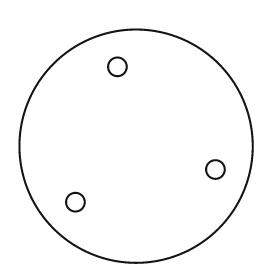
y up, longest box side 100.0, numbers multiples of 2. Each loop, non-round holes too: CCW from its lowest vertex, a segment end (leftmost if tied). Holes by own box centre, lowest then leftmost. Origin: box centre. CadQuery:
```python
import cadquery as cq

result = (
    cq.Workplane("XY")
    .moveTo(0.0, 0.0)
    .circle(50.0)
    .moveTo(-26.0, -24.0)
    .circle(4.0)
    .moveTo(34.0, -10.0)
    .circle(4.0)
    .moveTo(-8.0, 34.0)
    .circle(4.0)
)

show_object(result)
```